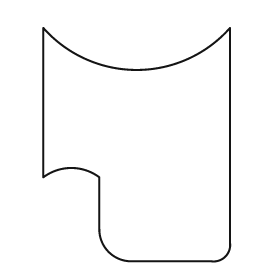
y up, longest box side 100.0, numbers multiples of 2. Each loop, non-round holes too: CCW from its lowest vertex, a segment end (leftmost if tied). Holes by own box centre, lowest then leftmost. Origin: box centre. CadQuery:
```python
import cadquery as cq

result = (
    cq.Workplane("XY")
    .moveTo(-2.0, -50.0)
    .lineTo(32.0, -50.0)
    .threePointArc((38.0, -48.0), (40.0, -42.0))
    .lineTo(40.0, 50.0)
    .threePointArc((0.0, 32.0), (-40.0, 50.0))
    .lineTo(-40.0, -14.0)
    .threePointArc((-28.0, -10.0), (-16.0, -14.0))
    .lineTo(-16.0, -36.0)
    .threePointArc((-12.0, -46.0), (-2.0, -50.0))
    .close()
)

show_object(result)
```